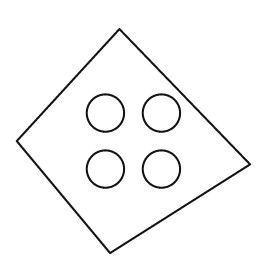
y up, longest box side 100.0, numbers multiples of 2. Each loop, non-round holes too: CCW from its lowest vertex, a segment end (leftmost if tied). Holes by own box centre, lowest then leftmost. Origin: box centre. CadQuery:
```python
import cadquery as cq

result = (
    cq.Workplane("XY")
    .moveTo(-10.0, -48.0)
    .lineTo(50.0, -10.0)
    .lineTo(-6.0, 48.0)
    .lineTo(-50.0, 0.0)
    .close()
    .moveTo(-12.0, -12.0)
    .circle(8.0)
    .moveTo(12.0, -12.0)
    .circle(8.0)
    .moveTo(-12.0, 12.0)
    .circle(8.0)
    .moveTo(12.0, 12.0)
    .circle(8.0)
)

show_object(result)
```